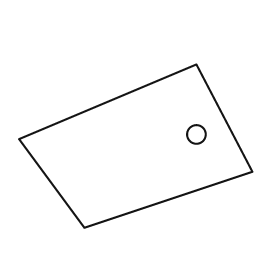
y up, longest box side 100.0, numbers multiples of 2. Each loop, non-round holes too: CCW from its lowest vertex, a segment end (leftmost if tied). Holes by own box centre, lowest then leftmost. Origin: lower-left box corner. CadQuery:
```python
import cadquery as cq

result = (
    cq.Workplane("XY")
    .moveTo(28.0, 0.0)
    .lineTo(100.0, 24.0)
    .lineTo(76.0, 70.0)
    .lineTo(0.0, 38.0)
    .close()
    .moveTo(76.0, 40.0)
    .circle(4.0)
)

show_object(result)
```